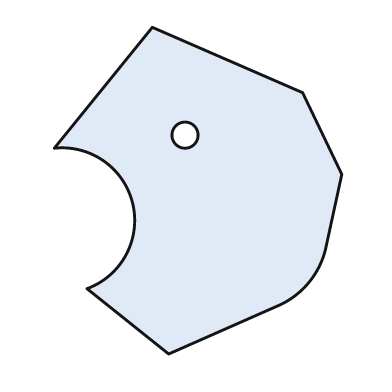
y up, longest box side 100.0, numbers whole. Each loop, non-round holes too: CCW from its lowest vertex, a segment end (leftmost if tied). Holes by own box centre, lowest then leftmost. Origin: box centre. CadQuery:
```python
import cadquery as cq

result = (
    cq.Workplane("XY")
    .moveTo(-9.0, -50.0)
    .lineTo(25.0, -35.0)
    .threePointArc((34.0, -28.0), (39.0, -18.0))
    .lineTo(44.0, 5.0)
    .lineTo(32.0, 30.0)
    .lineTo(-14.0, 50.0)
    .lineTo(-44.0, 13.0)
    .threePointArc((-20.0, -4.0), (-34.0, -30.0))
    .close()
    .moveTo(-4.0, 17.0)
    .circle(4.0)
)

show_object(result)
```